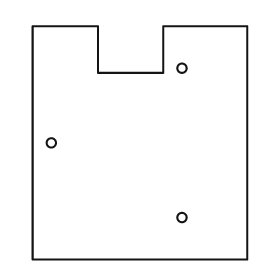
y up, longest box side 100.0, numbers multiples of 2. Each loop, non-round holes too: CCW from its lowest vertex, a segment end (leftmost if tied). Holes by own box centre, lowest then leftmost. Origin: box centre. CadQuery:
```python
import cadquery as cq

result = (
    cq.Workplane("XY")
    .moveTo(-46.0, -50.0)
    .lineTo(46.0, -50.0)
    .lineTo(46.0, 50.0)
    .lineTo(10.0, 50.0)
    .lineTo(10.0, 30.0)
    .lineTo(-18.0, 30.0)
    .lineTo(-18.0, 50.0)
    .lineTo(-46.0, 50.0)
    .close()
    .moveTo(18.0, -32.0)
    .circle(2.0)
    .moveTo(-38.0, 0.0)
    .circle(2.0)
    .moveTo(18.0, 32.0)
    .circle(2.0)
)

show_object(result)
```